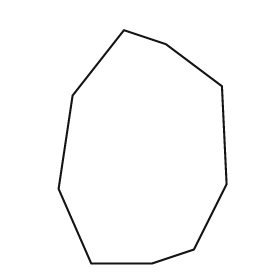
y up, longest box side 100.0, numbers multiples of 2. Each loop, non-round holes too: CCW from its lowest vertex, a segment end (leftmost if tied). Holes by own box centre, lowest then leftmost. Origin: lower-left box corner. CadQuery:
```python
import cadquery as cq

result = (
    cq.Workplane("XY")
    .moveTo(14.0, 0.0)
    .lineTo(40.0, 0.0)
    .lineTo(58.0, 6.0)
    .lineTo(72.0, 34.0)
    .lineTo(70.0, 76.0)
    .lineTo(46.0, 94.0)
    .lineTo(28.0, 100.0)
    .lineTo(6.0, 72.0)
    .lineTo(0.0, 32.0)
    .close()
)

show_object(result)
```